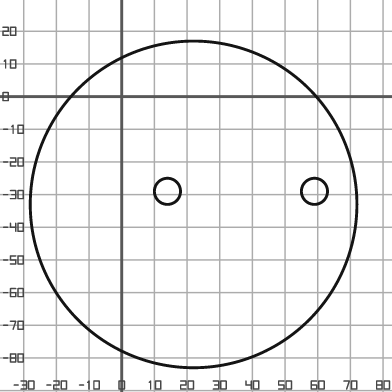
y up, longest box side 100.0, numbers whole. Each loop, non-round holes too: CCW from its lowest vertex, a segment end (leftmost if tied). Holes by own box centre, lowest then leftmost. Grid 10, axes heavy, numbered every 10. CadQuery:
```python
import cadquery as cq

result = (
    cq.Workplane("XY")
    .moveTo(22.0, -33.0)
    .circle(50.0)
    .moveTo(14.0, -29.0)
    .circle(4.0)
    .moveTo(59.0, -29.0)
    .circle(4.0)
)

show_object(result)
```